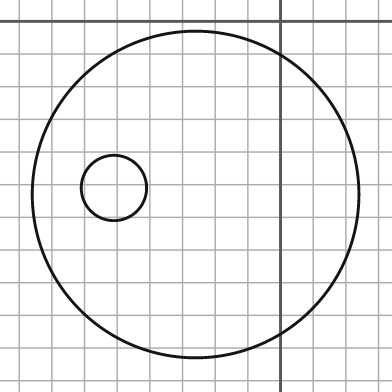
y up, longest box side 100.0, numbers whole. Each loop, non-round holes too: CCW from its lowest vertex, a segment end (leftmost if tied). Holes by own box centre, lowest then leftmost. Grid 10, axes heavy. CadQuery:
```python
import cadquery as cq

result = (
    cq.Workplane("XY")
    .moveTo(-26.0, -53.0)
    .circle(50.0)
    .moveTo(-51.0, -51.0)
    .circle(10.0)
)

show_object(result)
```